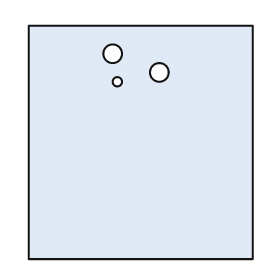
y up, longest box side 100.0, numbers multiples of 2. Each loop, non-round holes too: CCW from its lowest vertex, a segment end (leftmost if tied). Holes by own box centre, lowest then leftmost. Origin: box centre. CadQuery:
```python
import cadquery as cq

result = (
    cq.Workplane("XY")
    .moveTo(-48.0, -50.0)
    .lineTo(48.0, -50.0)
    .lineTo(48.0, 50.0)
    .lineTo(-48.0, 50.0)
    .close()
    .moveTo(-10.0, 26.0)
    .circle(2.0)
    .moveTo(8.0, 30.0)
    .circle(4.0)
    .moveTo(-12.0, 38.0)
    .circle(4.0)
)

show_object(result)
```